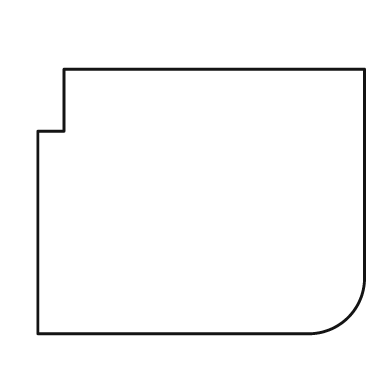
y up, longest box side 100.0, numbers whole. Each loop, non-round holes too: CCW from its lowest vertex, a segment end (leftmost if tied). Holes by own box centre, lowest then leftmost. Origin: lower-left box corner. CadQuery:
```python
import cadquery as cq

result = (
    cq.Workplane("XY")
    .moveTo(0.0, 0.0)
    .lineTo(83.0, 0.0)
    .threePointArc((95.0, 5.0), (100.0, 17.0))
    .lineTo(100.0, 81.0)
    .lineTo(8.0, 81.0)
    .lineTo(8.0, 62.0)
    .lineTo(0.0, 62.0)
    .close()
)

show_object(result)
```